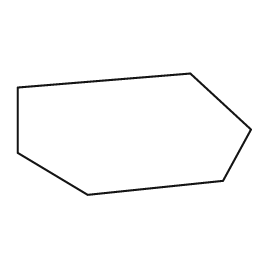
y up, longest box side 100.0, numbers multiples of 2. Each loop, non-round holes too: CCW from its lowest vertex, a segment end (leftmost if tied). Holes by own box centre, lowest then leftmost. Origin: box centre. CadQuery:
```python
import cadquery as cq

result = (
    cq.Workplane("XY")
    .moveTo(-20.0, -26.0)
    .lineTo(38.0, -20.0)
    .lineTo(50.0, 2.0)
    .lineTo(24.0, 26.0)
    .lineTo(-50.0, 20.0)
    .lineTo(-50.0, -8.0)
    .close()
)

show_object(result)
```